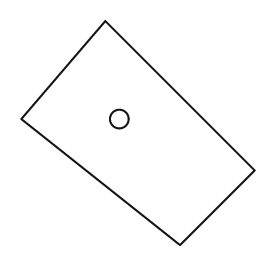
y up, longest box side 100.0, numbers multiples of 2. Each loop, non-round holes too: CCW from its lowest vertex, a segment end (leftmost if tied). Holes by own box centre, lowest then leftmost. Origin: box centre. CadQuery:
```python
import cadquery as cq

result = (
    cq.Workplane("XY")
    .moveTo(18.0, -48.0)
    .lineTo(50.0, -16.0)
    .lineTo(-14.0, 48.0)
    .lineTo(-50.0, 6.0)
    .close()
    .moveTo(-8.0, 6.0)
    .circle(4.0)
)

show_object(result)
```